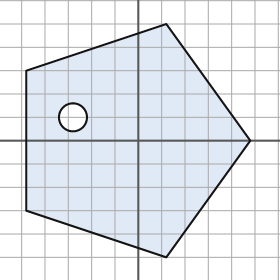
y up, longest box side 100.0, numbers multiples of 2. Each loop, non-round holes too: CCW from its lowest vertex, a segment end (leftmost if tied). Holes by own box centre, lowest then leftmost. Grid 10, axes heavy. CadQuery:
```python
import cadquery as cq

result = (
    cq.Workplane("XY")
    .moveTo(12.0, -50.0)
    .lineTo(48.0, 0.0)
    .lineTo(12.0, 50.0)
    .lineTo(-48.0, 30.0)
    .lineTo(-48.0, -30.0)
    .close()
    .moveTo(-28.0, 10.0)
    .circle(6.0)
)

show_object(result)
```